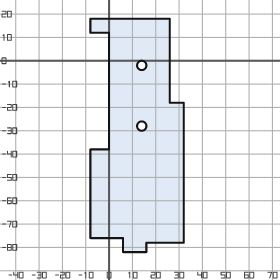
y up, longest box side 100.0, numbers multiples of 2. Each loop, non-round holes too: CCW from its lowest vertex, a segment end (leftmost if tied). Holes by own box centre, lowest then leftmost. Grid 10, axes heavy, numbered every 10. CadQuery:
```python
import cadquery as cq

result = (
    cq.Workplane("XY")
    .moveTo(6.0, -82.0)
    .lineTo(16.0, -82.0)
    .lineTo(16.0, -78.0)
    .lineTo(32.0, -78.0)
    .lineTo(32.0, -18.0)
    .lineTo(26.0, -18.0)
    .lineTo(26.0, 18.0)
    .lineTo(-8.0, 18.0)
    .lineTo(-8.0, 12.0)
    .lineTo(0.0, 12.0)
    .lineTo(0.0, -38.0)
    .lineTo(-8.0, -38.0)
    .lineTo(-8.0, -76.0)
    .lineTo(6.0, -76.0)
    .close()
    .moveTo(14.0, -28.0)
    .circle(2.0)
    .moveTo(14.0, -2.0)
    .circle(2.0)
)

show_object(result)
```